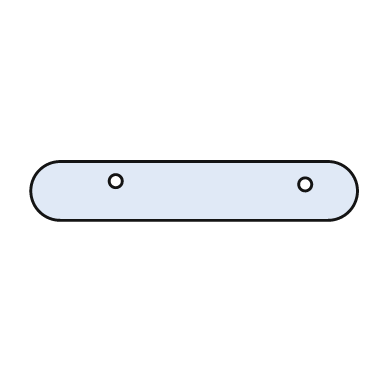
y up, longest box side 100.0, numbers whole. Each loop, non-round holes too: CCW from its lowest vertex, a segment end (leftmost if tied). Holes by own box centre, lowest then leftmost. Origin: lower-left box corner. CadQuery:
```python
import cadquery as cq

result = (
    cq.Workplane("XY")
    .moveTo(9.0, 0.0)
    .lineTo(91.0, 0.0)
    .threePointArc((100.0, 9.0), (91.0, 18.0))
    .lineTo(9.0, 18.0)
    .threePointArc((0.0, 9.0), (9.0, 0.0))
    .close()
    .moveTo(84.0, 11.0)
    .circle(2.0)
    .moveTo(26.0, 12.0)
    .circle(2.0)
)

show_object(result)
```